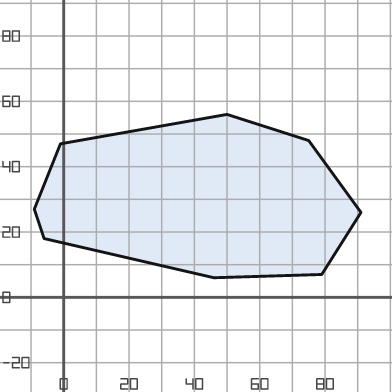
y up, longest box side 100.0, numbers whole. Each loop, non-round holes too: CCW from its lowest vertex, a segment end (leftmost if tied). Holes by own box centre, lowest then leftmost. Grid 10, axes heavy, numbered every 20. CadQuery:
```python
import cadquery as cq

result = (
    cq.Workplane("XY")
    .moveTo(46.0, 6.0)
    .lineTo(79.0, 7.0)
    .lineTo(91.0, 26.0)
    .lineTo(75.0, 48.0)
    .lineTo(50.0, 56.0)
    .lineTo(-1.0, 47.0)
    .lineTo(-9.0, 27.0)
    .lineTo(-6.0, 18.0)
    .close()
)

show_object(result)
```